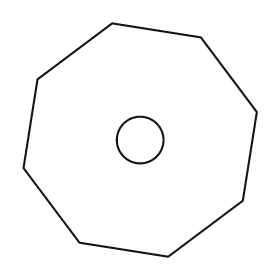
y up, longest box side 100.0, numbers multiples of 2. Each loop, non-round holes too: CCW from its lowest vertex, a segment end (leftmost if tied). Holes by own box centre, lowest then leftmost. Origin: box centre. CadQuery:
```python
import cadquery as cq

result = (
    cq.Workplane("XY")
    .moveTo(12.0, -50.0)
    .lineTo(44.0, -26.0)
    .lineTo(50.0, 12.0)
    .lineTo(26.0, 44.0)
    .lineTo(-12.0, 50.0)
    .lineTo(-44.0, 26.0)
    .lineTo(-50.0, -12.0)
    .lineTo(-26.0, -44.0)
    .close()
    .moveTo(0.0, 0.0)
    .circle(10.0)
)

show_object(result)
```